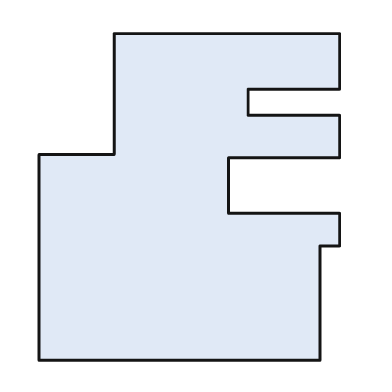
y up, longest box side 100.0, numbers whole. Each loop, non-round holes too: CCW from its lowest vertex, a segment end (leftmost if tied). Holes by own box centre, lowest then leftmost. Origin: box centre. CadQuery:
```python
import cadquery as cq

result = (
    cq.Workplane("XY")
    .moveTo(-46.0, -50.0)
    .lineTo(40.0, -50.0)
    .lineTo(40.0, -15.0)
    .lineTo(46.0, -15.0)
    .lineTo(46.0, -5.0)
    .lineTo(12.0, -5.0)
    .lineTo(12.0, 12.0)
    .lineTo(46.0, 12.0)
    .lineTo(46.0, 25.0)
    .lineTo(18.0, 25.0)
    .lineTo(18.0, 33.0)
    .lineTo(46.0, 33.0)
    .lineTo(46.0, 50.0)
    .lineTo(-23.0, 50.0)
    .lineTo(-23.0, 13.0)
    .lineTo(-46.0, 13.0)
    .close()
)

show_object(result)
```